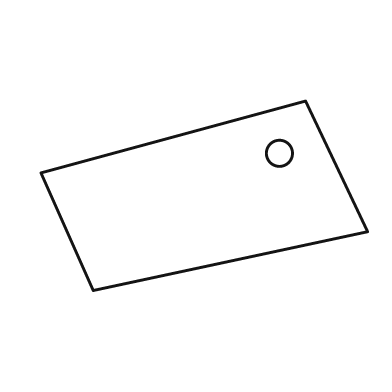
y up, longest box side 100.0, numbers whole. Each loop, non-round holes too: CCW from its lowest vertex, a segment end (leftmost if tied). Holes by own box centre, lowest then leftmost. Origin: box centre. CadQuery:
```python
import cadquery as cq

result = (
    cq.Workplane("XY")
    .moveTo(-34.0, -29.0)
    .lineTo(50.0, -11.0)
    .lineTo(31.0, 29.0)
    .lineTo(-50.0, 7.0)
    .close()
    .moveTo(23.0, 13.0)
    .circle(4.0)
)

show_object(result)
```